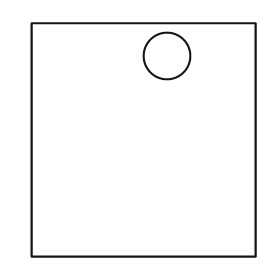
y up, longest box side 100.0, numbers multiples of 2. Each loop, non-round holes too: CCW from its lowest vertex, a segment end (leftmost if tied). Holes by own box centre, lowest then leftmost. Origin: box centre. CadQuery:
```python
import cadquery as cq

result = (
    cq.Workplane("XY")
    .moveTo(-48.0, -50.0)
    .lineTo(48.0, -50.0)
    .lineTo(48.0, 50.0)
    .lineTo(-48.0, 50.0)
    .close()
    .moveTo(10.0, 36.0)
    .circle(10.0)
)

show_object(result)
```